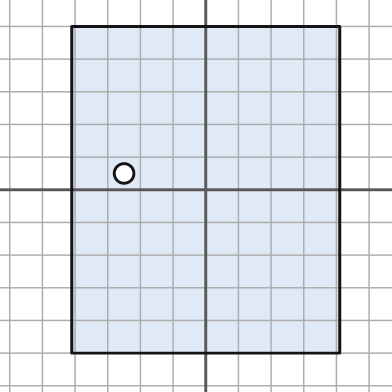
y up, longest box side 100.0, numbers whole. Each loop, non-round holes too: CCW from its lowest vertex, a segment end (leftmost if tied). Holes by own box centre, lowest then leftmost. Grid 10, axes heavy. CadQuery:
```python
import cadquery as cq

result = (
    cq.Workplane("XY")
    .moveTo(-41.0, -50.0)
    .lineTo(41.0, -50.0)
    .lineTo(41.0, 50.0)
    .lineTo(-41.0, 50.0)
    .close()
    .moveTo(-25.0, 5.0)
    .circle(3.0)
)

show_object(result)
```